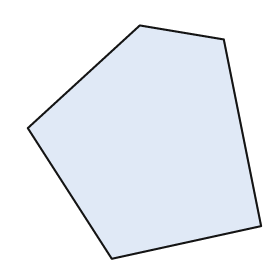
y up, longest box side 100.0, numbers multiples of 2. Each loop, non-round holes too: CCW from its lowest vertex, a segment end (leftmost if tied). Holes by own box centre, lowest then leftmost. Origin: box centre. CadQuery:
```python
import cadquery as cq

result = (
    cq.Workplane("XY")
    .moveTo(-14.0, -50.0)
    .lineTo(50.0, -36.0)
    .lineTo(34.0, 44.0)
    .lineTo(-2.0, 50.0)
    .lineTo(-50.0, 6.0)
    .close()
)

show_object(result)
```